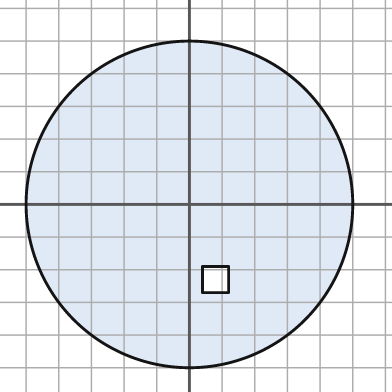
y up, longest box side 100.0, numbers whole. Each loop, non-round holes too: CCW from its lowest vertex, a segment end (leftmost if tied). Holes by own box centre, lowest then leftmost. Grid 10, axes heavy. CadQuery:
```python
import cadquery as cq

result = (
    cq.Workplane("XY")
    .moveTo(0.0, 0.0)
    .circle(50.0)
    .moveTo(4.0, -27.0)
    .lineTo(12.0, -27.0)
    .lineTo(12.0, -19.0)
    .lineTo(4.0, -19.0)
    .close()
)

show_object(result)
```